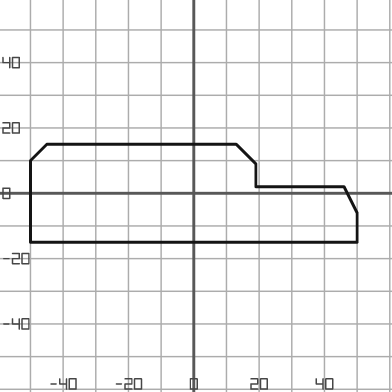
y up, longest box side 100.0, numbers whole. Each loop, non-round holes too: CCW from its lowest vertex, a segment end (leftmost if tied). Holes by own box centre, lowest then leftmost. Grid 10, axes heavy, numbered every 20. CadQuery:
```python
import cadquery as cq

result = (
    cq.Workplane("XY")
    .moveTo(-50.0, -15.0)
    .lineTo(50.0, -15.0)
    .lineTo(50.0, -6.0)
    .lineTo(46.0, 2.0)
    .lineTo(19.0, 2.0)
    .lineTo(19.0, 9.0)
    .lineTo(13.0, 15.0)
    .lineTo(-45.0, 15.0)
    .lineTo(-50.0, 10.0)
    .close()
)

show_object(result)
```